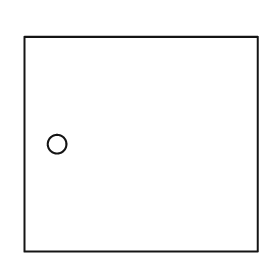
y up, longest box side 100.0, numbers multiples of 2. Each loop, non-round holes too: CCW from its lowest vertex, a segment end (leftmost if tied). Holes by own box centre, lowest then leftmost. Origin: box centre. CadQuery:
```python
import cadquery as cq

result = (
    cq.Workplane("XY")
    .moveTo(-50.0, -46.0)
    .lineTo(50.0, -46.0)
    .lineTo(50.0, 46.0)
    .lineTo(-50.0, 46.0)
    .close()
    .moveTo(-36.0, 0.0)
    .circle(4.0)
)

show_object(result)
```